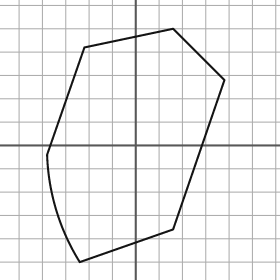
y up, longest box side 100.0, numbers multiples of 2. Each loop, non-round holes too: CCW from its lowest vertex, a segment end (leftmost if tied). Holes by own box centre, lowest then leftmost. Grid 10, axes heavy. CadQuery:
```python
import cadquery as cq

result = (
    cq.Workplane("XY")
    .moveTo(-24.0, -50.0)
    .lineTo(16.0, -36.0)
    .lineTo(38.0, 28.0)
    .lineTo(16.0, 50.0)
    .lineTo(-22.0, 42.0)
    .lineTo(-38.0, -4.0)
    .threePointArc((-34.0, -28.0), (-24.0, -50.0))
    .close()
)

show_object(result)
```